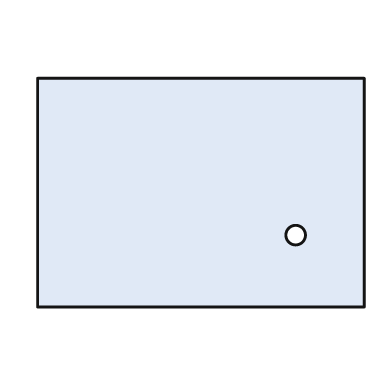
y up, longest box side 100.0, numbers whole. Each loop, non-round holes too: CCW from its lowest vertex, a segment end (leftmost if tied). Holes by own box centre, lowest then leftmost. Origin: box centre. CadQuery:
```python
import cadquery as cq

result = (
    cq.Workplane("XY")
    .moveTo(-50.0, -35.0)
    .lineTo(50.0, -35.0)
    .lineTo(50.0, 35.0)
    .lineTo(-50.0, 35.0)
    .close()
    .moveTo(29.0, -13.0)
    .circle(3.0)
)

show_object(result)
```